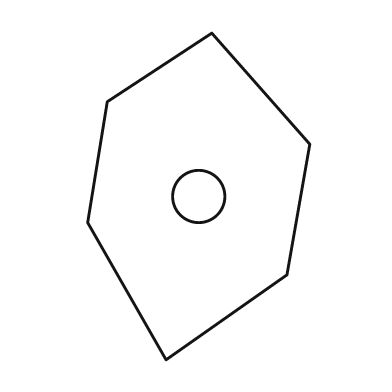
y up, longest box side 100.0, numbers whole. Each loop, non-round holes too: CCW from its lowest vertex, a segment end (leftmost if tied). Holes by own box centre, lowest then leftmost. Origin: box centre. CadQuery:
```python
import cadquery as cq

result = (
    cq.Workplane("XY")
    .moveTo(-10.0, -50.0)
    .lineTo(27.0, -24.0)
    .lineTo(34.0, 16.0)
    .lineTo(4.0, 50.0)
    .lineTo(-28.0, 29.0)
    .lineTo(-34.0, -8.0)
    .close()
    .moveTo(0.0, 0.0)
    .circle(8.0)
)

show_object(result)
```